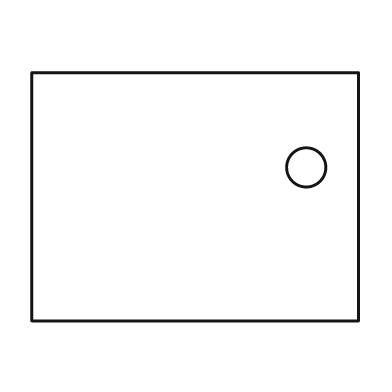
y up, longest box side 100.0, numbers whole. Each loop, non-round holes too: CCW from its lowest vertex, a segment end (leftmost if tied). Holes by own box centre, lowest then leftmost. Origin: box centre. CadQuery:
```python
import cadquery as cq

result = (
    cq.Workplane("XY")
    .moveTo(-50.0, -38.0)
    .lineTo(50.0, -38.0)
    .lineTo(50.0, 38.0)
    .lineTo(-50.0, 38.0)
    .close()
    .moveTo(34.0, 9.0)
    .circle(6.0)
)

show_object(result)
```